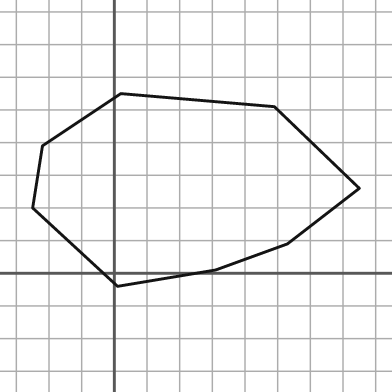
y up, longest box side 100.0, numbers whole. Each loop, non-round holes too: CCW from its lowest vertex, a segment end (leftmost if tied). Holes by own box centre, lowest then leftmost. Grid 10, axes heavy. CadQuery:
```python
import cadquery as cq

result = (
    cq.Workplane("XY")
    .moveTo(1.0, -4.0)
    .lineTo(31.0, 1.0)
    .lineTo(53.0, 9.0)
    .lineTo(75.0, 26.0)
    .lineTo(49.0, 51.0)
    .lineTo(2.0, 55.0)
    .lineTo(-22.0, 39.0)
    .lineTo(-25.0, 20.0)
    .close()
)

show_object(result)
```